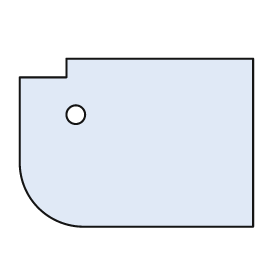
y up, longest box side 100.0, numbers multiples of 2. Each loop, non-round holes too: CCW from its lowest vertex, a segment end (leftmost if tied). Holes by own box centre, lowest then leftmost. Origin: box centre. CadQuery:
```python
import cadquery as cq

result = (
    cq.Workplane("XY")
    .moveTo(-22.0, -36.0)
    .lineTo(50.0, -36.0)
    .lineTo(50.0, 36.0)
    .lineTo(-30.0, 36.0)
    .lineTo(-30.0, 28.0)
    .lineTo(-50.0, 28.0)
    .lineTo(-50.0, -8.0)
    .threePointArc((-42.0, -28.0), (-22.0, -36.0))
    .close()
    .moveTo(-26.0, 12.0)
    .circle(4.0)
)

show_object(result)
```